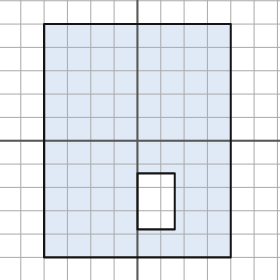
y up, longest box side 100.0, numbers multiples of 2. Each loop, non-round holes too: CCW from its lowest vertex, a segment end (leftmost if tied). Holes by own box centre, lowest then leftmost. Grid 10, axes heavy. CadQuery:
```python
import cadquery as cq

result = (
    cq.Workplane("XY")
    .moveTo(-40.0, -50.0)
    .lineTo(40.0, -50.0)
    .lineTo(40.0, 50.0)
    .lineTo(-40.0, 50.0)
    .close()
    .moveTo(0.0, -38.0)
    .lineTo(16.0, -38.0)
    .lineTo(16.0, -14.0)
    .lineTo(0.0, -14.0)
    .close()
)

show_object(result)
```